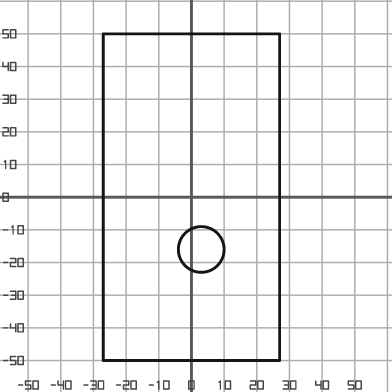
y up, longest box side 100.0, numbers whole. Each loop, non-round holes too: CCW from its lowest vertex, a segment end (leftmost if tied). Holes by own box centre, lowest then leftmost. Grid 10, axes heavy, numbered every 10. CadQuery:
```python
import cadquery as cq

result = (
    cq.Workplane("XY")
    .moveTo(-27.0, -50.0)
    .lineTo(27.0, -50.0)
    .lineTo(27.0, 50.0)
    .lineTo(-27.0, 50.0)
    .close()
    .moveTo(3.0, -16.0)
    .circle(7.0)
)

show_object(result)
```